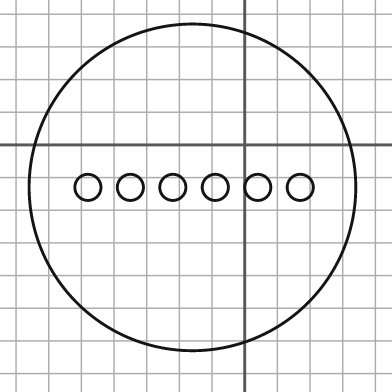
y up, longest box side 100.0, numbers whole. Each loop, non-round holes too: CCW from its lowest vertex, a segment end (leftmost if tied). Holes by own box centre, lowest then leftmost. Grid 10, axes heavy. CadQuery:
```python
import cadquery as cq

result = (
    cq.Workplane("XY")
    .moveTo(-16.0, -13.0)
    .circle(50.0)
    .moveTo(-48.0, -13.0)
    .circle(4.0)
    .moveTo(-35.0, -13.0)
    .circle(4.0)
    .moveTo(-22.0, -13.0)
    .circle(4.0)
    .moveTo(-9.0, -13.0)
    .circle(4.0)
    .moveTo(4.0, -13.0)
    .circle(4.0)
    .moveTo(17.0, -13.0)
    .circle(4.0)
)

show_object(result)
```